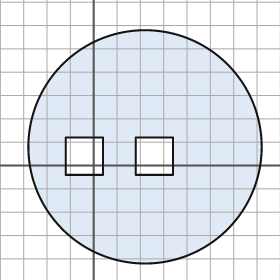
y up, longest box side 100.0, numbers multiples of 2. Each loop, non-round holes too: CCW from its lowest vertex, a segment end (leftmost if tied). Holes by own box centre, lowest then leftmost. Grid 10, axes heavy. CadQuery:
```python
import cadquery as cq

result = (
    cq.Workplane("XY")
    .moveTo(22.0, 8.0)
    .circle(50.0)
    .moveTo(-12.0, -4.0)
    .lineTo(4.0, -4.0)
    .lineTo(4.0, 12.0)
    .lineTo(-12.0, 12.0)
    .close()
    .moveTo(18.0, -4.0)
    .lineTo(34.0, -4.0)
    .lineTo(34.0, 12.0)
    .lineTo(18.0, 12.0)
    .close()
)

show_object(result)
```